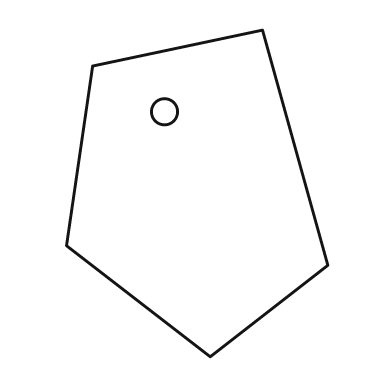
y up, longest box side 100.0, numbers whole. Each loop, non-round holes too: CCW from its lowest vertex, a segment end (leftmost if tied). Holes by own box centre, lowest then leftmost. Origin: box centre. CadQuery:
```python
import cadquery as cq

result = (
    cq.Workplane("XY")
    .moveTo(4.0, -50.0)
    .lineTo(40.0, -22.0)
    .lineTo(20.0, 50.0)
    .lineTo(-32.0, 39.0)
    .lineTo(-40.0, -16.0)
    .close()
    .moveTo(-10.0, 25.0)
    .circle(4.0)
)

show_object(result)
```